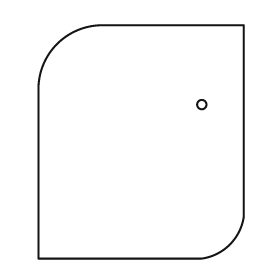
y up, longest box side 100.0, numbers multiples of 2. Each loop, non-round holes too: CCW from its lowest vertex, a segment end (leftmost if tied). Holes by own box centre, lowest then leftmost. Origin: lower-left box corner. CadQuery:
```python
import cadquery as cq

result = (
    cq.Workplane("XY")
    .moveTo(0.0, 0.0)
    .lineTo(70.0, 0.0)
    .threePointArc((82.0, 6.0), (88.0, 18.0))
    .lineTo(88.0, 100.0)
    .lineTo(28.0, 100.0)
    .threePointArc((8.0, 92.0), (0.0, 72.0))
    .close()
    .moveTo(70.0, 66.0)
    .circle(2.0)
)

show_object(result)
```